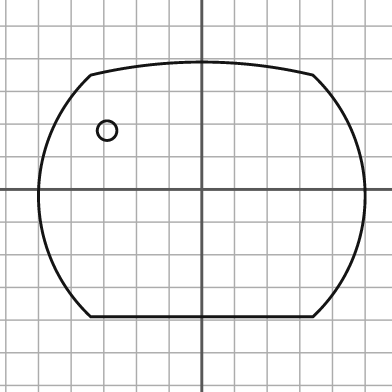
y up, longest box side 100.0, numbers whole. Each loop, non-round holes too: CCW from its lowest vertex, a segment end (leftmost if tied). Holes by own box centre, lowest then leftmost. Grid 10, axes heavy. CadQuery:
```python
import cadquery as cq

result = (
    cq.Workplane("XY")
    .moveTo(-34.0, -39.0)
    .lineTo(34.0, -39.0)
    .threePointArc((50.0, -2.0), (34.0, 35.0))
    .threePointArc((0.0, 39.0), (-34.0, 35.0))
    .threePointArc((-50.0, -2.0), (-34.0, -39.0))
    .close()
    .moveTo(-29.0, 18.0)
    .circle(3.0)
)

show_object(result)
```